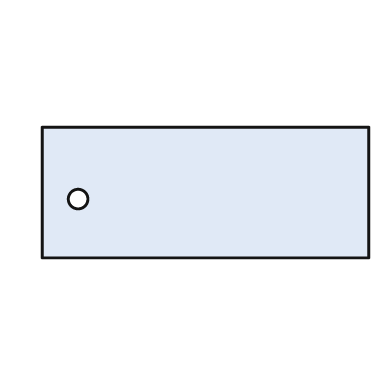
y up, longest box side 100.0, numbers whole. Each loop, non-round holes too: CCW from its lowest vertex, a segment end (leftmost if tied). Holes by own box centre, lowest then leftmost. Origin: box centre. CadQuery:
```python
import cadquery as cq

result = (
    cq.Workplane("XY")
    .moveTo(-50.0, -20.0)
    .lineTo(50.0, -20.0)
    .lineTo(50.0, 20.0)
    .lineTo(-50.0, 20.0)
    .close()
    .moveTo(-39.0, -2.0)
    .circle(3.0)
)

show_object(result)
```